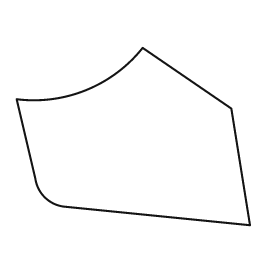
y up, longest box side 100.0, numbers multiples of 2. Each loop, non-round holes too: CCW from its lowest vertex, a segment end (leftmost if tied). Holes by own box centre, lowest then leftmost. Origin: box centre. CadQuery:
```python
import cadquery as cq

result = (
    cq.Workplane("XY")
    .moveTo(50.0, -38.0)
    .lineTo(42.0, 12.0)
    .lineTo(4.0, 38.0)
    .threePointArc((-20.0, 20.0), (-50.0, 16.0))
    .lineTo(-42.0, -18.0)
    .threePointArc((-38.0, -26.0), (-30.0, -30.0))
    .close()
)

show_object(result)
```